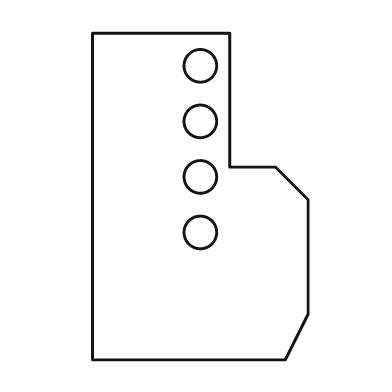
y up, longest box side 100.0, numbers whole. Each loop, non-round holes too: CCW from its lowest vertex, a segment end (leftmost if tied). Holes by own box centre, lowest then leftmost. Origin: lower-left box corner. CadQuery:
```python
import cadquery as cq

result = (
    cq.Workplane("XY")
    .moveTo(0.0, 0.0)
    .lineTo(59.0, 0.0)
    .lineTo(66.0, 14.0)
    .lineTo(66.0, 49.0)
    .lineTo(56.0, 59.0)
    .lineTo(42.0, 59.0)
    .lineTo(42.0, 100.0)
    .lineTo(0.0, 100.0)
    .close()
    .moveTo(33.0, 39.0)
    .circle(5.0)
    .moveTo(33.0, 56.0)
    .circle(5.0)
    .moveTo(33.0, 73.0)
    .circle(5.0)
    .moveTo(33.0, 90.0)
    .circle(5.0)
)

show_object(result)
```